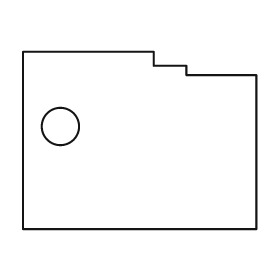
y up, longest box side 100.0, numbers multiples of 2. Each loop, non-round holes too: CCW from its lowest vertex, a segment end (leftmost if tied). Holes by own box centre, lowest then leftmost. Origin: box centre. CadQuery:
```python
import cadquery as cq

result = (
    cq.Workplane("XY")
    .moveTo(-50.0, -38.0)
    .lineTo(50.0, -38.0)
    .lineTo(50.0, 28.0)
    .lineTo(20.0, 28.0)
    .lineTo(20.0, 32.0)
    .lineTo(6.0, 32.0)
    .lineTo(6.0, 38.0)
    .lineTo(-50.0, 38.0)
    .close()
    .moveTo(-34.0, 6.0)
    .circle(8.0)
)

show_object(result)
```